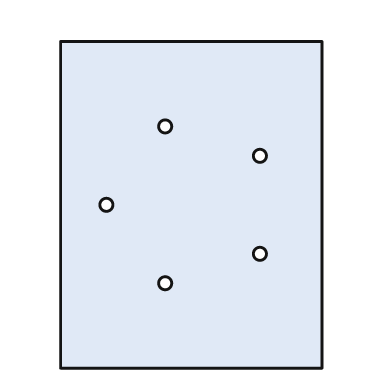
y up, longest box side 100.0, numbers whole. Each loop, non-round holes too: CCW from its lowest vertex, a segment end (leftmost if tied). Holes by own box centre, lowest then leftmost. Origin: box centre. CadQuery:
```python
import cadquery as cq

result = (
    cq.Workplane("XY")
    .moveTo(-40.0, -50.0)
    .lineTo(40.0, -50.0)
    .lineTo(40.0, 50.0)
    .lineTo(-40.0, 50.0)
    .close()
    .moveTo(-8.0, -24.0)
    .circle(2.0)
    .moveTo(21.0, -15.0)
    .circle(2.0)
    .moveTo(-26.0, 0.0)
    .circle(2.0)
    .moveTo(21.0, 15.0)
    .circle(2.0)
    .moveTo(-8.0, 24.0)
    .circle(2.0)
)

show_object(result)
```